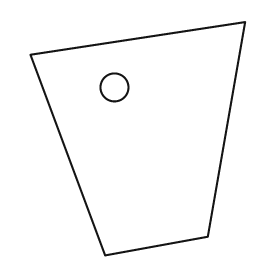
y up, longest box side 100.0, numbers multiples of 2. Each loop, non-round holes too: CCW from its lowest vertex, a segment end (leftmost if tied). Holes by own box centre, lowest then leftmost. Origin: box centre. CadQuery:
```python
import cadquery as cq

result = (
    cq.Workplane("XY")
    .moveTo(-14.0, -50.0)
    .lineTo(30.0, -42.0)
    .lineTo(46.0, 50.0)
    .lineTo(-46.0, 36.0)
    .close()
    .moveTo(-10.0, 22.0)
    .circle(6.0)
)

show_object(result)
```